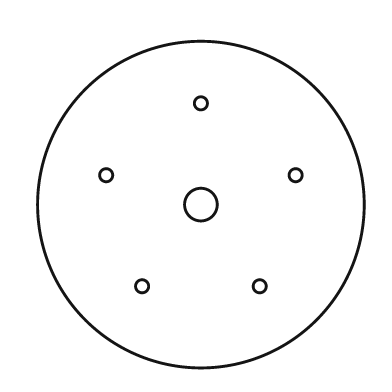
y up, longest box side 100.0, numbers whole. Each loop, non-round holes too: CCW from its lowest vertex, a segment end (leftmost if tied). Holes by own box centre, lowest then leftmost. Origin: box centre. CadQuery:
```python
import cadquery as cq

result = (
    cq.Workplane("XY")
    .moveTo(0.0, 0.0)
    .circle(50.0)
    .moveTo(-18.0, -25.0)
    .circle(2.0)
    .moveTo(18.0, -25.0)
    .circle(2.0)
    .moveTo(0.0, 0.0)
    .circle(5.0)
    .moveTo(-29.0, 9.0)
    .circle(2.0)
    .moveTo(29.0, 9.0)
    .circle(2.0)
    .moveTo(0.0, 31.0)
    .circle(2.0)
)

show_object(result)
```